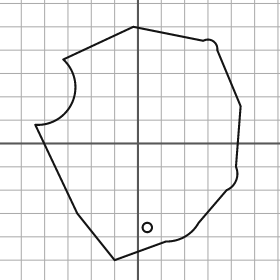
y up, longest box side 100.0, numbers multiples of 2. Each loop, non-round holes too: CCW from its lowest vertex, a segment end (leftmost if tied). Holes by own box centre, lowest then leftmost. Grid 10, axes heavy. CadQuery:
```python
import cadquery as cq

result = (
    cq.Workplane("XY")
    .moveTo(-10.0, -50.0)
    .lineTo(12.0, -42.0)
    .threePointArc((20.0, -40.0), (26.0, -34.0))
    .lineTo(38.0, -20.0)
    .threePointArc((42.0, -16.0), (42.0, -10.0))
    .lineTo(44.0, 16.0)
    .lineTo(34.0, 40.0)
    .threePointArc((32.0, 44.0), (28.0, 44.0))
    .lineTo(-2.0, 50.0)
    .lineTo(-32.0, 36.0)
    .threePointArc((-28.0, 18.0), (-44.0, 8.0))
    .lineTo(-26.0, -30.0)
    .close()
    .moveTo(4.0, -36.0)
    .circle(2.0)
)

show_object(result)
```